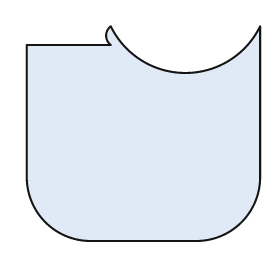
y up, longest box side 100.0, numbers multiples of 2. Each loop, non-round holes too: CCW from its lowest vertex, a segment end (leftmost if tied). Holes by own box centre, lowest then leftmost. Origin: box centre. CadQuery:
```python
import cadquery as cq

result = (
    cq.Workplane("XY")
    .moveTo(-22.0, -46.0)
    .lineTo(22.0, -46.0)
    .threePointArc((42.0, -38.0), (50.0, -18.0))
    .lineTo(50.0, 46.0)
    .threePointArc((18.0, 26.0), (-14.0, 46.0))
    .threePointArc((-16.0, 42.0), (-14.0, 38.0))
    .lineTo(-50.0, 38.0)
    .lineTo(-50.0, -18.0)
    .threePointArc((-42.0, -38.0), (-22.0, -46.0))
    .close()
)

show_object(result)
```